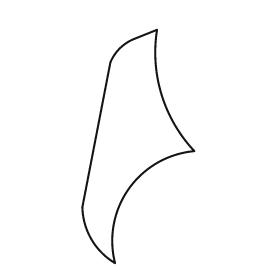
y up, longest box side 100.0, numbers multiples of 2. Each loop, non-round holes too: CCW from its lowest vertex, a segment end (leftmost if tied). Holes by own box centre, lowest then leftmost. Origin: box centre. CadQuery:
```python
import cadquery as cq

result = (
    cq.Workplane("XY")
    .moveTo(-10.0, -50.0)
    .threePointArc((-4.0, -18.0), (24.0, -2.0))
    .threePointArc((10.0, 22.0), (8.0, 50.0))
    .lineTo(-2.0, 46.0)
    .threePointArc((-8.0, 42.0), (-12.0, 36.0))
    .lineTo(-24.0, -26.0)
    .threePointArc((-20.0, -40.0), (-10.0, -50.0))
    .close()
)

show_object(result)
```